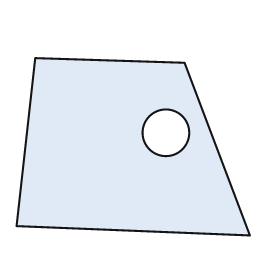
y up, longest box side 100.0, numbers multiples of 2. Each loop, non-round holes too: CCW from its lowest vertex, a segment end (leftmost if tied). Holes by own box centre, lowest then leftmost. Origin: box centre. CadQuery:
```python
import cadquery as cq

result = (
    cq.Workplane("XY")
    .moveTo(50.0, -38.0)
    .lineTo(22.0, 36.0)
    .lineTo(-42.0, 38.0)
    .lineTo(-50.0, -34.0)
    .close()
    .moveTo(14.0, 6.0)
    .circle(10.0)
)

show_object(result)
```